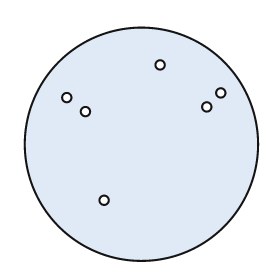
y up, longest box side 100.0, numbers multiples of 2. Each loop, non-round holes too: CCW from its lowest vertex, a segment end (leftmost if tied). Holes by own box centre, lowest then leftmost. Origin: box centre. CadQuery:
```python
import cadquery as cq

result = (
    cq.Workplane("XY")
    .moveTo(0.0, 0.0)
    .circle(50.0)
    .moveTo(-16.0, -24.0)
    .circle(2.0)
    .moveTo(-24.0, 14.0)
    .circle(2.0)
    .moveTo(28.0, 16.0)
    .circle(2.0)
    .moveTo(-32.0, 20.0)
    .circle(2.0)
    .moveTo(34.0, 22.0)
    .circle(2.0)
    .moveTo(8.0, 34.0)
    .circle(2.0)
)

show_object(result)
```